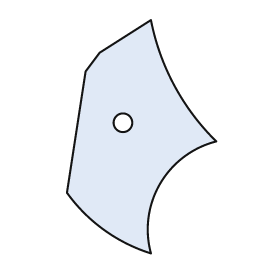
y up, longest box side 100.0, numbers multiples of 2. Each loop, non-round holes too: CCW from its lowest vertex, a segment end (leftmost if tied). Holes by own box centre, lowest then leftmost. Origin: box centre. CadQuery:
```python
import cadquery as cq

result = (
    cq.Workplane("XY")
    .moveTo(4.0, -50.0)
    .threePointArc((8.0, -20.0), (32.0, -2.0))
    .threePointArc((14.0, 22.0), (4.0, 50.0))
    .lineTo(-18.0, 36.0)
    .lineTo(-24.0, 28.0)
    .lineTo(-32.0, -24.0)
    .threePointArc((-16.0, -40.0), (4.0, -50.0))
    .close()
    .moveTo(-8.0, 6.0)
    .circle(4.0)
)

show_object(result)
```